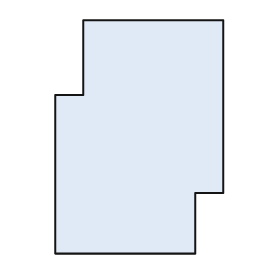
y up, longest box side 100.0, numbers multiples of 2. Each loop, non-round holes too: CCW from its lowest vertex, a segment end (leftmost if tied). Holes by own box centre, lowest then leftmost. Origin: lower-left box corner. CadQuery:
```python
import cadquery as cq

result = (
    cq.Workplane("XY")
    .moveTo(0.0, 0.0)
    .lineTo(60.0, 0.0)
    .lineTo(60.0, 26.0)
    .lineTo(72.0, 26.0)
    .lineTo(72.0, 100.0)
    .lineTo(12.0, 100.0)
    .lineTo(12.0, 68.0)
    .lineTo(0.0, 68.0)
    .close()
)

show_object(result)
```